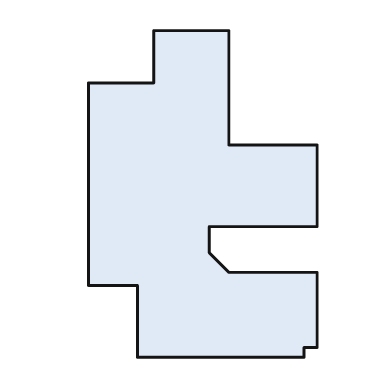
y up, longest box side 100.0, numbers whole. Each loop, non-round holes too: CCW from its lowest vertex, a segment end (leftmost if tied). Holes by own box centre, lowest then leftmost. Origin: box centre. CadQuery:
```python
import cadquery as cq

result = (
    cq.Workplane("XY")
    .moveTo(-20.0, -50.0)
    .lineTo(31.0, -50.0)
    .lineTo(31.0, -47.0)
    .lineTo(35.0, -47.0)
    .lineTo(35.0, -24.0)
    .lineTo(8.0, -24.0)
    .lineTo(2.0, -18.0)
    .lineTo(2.0, -10.0)
    .lineTo(35.0, -10.0)
    .lineTo(35.0, 15.0)
    .lineTo(8.0, 15.0)
    .lineTo(8.0, 50.0)
    .lineTo(-15.0, 50.0)
    .lineTo(-15.0, 34.0)
    .lineTo(-35.0, 34.0)
    .lineTo(-35.0, -28.0)
    .lineTo(-20.0, -28.0)
    .close()
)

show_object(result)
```